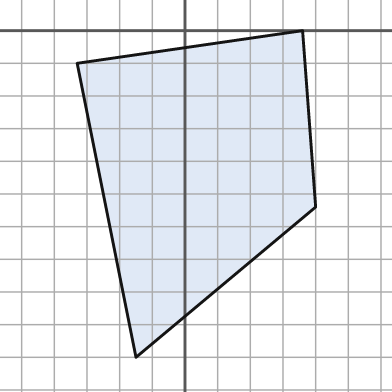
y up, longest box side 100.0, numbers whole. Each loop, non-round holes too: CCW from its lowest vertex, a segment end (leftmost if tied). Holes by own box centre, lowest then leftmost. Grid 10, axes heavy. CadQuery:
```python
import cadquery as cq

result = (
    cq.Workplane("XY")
    .moveTo(-15.0, -100.0)
    .lineTo(40.0, -54.0)
    .lineTo(36.0, 0.0)
    .lineTo(-33.0, -10.0)
    .close()
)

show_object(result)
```